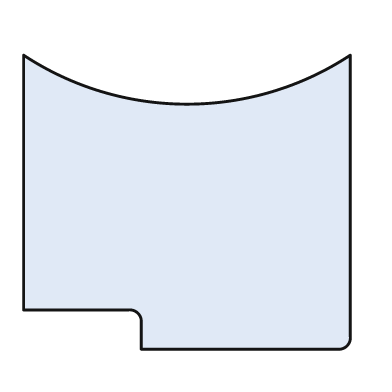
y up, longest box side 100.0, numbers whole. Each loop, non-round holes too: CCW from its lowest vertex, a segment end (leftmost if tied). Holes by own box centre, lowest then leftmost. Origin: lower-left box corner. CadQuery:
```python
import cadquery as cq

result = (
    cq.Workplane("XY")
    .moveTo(36.0, 0.0)
    .lineTo(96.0, 0.0)
    .threePointArc((99.0, 1.0), (100.0, 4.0))
    .lineTo(100.0, 90.0)
    .threePointArc((50.0, 75.0), (0.0, 90.0))
    .lineTo(0.0, 12.0)
    .lineTo(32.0, 12.0)
    .threePointArc((35.0, 11.0), (36.0, 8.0))
    .close()
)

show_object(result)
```